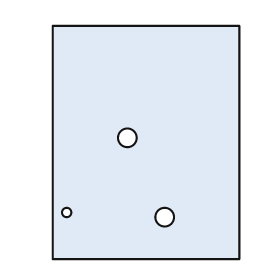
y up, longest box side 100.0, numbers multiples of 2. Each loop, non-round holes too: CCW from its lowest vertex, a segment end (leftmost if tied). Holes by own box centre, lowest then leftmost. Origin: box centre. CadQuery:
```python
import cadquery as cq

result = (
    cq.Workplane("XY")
    .moveTo(-40.0, -50.0)
    .lineTo(40.0, -50.0)
    .lineTo(40.0, 50.0)
    .lineTo(-40.0, 50.0)
    .close()
    .moveTo(8.0, -32.0)
    .circle(4.0)
    .moveTo(-34.0, -30.0)
    .circle(2.0)
    .moveTo(-8.0, 2.0)
    .circle(4.0)
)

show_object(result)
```